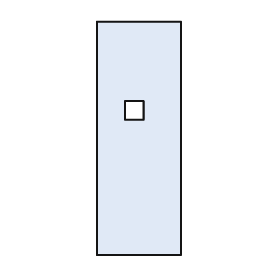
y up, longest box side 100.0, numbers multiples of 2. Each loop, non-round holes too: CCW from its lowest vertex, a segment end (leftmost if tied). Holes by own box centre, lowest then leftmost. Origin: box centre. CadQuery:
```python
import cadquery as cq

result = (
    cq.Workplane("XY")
    .moveTo(-18.0, -50.0)
    .lineTo(18.0, -50.0)
    .lineTo(18.0, 50.0)
    .lineTo(-18.0, 50.0)
    .close()
    .moveTo(-6.0, 8.0)
    .lineTo(2.0, 8.0)
    .lineTo(2.0, 16.0)
    .lineTo(-6.0, 16.0)
    .close()
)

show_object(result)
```